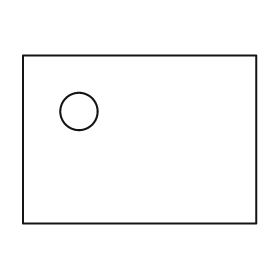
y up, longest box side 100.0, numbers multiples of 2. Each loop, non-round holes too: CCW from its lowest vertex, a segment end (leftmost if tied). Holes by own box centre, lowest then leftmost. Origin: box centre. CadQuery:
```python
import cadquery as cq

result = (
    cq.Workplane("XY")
    .moveTo(-50.0, -36.0)
    .lineTo(50.0, -36.0)
    .lineTo(50.0, 36.0)
    .lineTo(-50.0, 36.0)
    .close()
    .moveTo(-26.0, 12.0)
    .circle(8.0)
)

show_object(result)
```